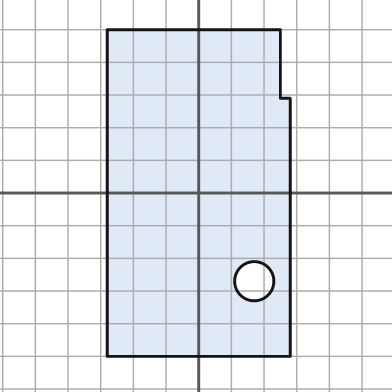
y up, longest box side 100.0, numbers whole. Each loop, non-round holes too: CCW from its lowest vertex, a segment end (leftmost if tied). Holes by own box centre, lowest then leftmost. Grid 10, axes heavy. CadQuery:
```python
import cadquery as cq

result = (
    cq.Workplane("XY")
    .moveTo(-28.0, -50.0)
    .lineTo(28.0, -50.0)
    .lineTo(28.0, 29.0)
    .lineTo(25.0, 29.0)
    .lineTo(25.0, 50.0)
    .lineTo(-28.0, 50.0)
    .close()
    .moveTo(17.0, -27.0)
    .circle(6.0)
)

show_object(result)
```